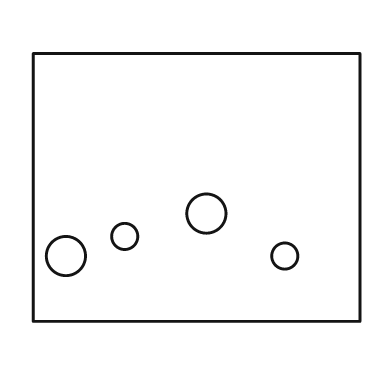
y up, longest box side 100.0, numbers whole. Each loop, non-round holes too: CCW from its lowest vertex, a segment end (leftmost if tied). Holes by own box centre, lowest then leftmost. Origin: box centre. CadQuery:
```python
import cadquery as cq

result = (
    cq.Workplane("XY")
    .moveTo(-50.0, -41.0)
    .lineTo(50.0, -41.0)
    .lineTo(50.0, 41.0)
    .lineTo(-50.0, 41.0)
    .close()
    .moveTo(-40.0, -21.0)
    .circle(6.0)
    .moveTo(27.0, -21.0)
    .circle(4.0)
    .moveTo(-22.0, -15.0)
    .circle(4.0)
    .moveTo(3.0, -8.0)
    .circle(6.0)
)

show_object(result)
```